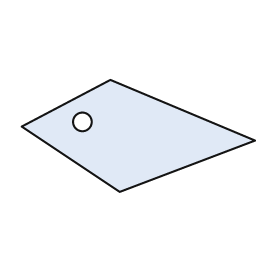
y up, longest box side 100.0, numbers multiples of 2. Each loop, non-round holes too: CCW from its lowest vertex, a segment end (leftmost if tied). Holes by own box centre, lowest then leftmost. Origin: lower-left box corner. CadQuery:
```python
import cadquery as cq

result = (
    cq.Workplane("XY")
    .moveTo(42.0, 0.0)
    .lineTo(100.0, 22.0)
    .lineTo(38.0, 48.0)
    .lineTo(0.0, 28.0)
    .close()
    .moveTo(26.0, 30.0)
    .circle(4.0)
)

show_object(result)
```